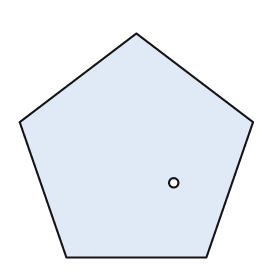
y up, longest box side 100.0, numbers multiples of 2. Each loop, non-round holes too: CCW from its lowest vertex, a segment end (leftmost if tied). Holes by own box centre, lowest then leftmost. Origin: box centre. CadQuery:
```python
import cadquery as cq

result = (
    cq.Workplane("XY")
    .moveTo(-30.0, -48.0)
    .lineTo(30.0, -48.0)
    .lineTo(50.0, 10.0)
    .lineTo(0.0, 48.0)
    .lineTo(-50.0, 10.0)
    .close()
    .moveTo(16.0, -16.0)
    .circle(2.0)
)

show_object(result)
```